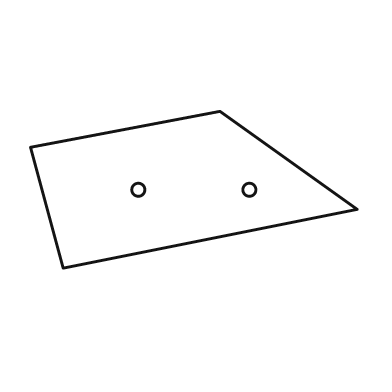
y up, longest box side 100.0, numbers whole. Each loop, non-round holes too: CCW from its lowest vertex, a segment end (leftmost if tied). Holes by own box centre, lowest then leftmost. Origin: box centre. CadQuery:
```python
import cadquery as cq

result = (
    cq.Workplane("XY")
    .moveTo(-40.0, -24.0)
    .lineTo(50.0, -6.0)
    .lineTo(8.0, 24.0)
    .lineTo(-50.0, 13.0)
    .close()
    .moveTo(-17.0, 0.0)
    .circle(2.0)
    .moveTo(17.0, 0.0)
    .circle(2.0)
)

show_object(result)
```